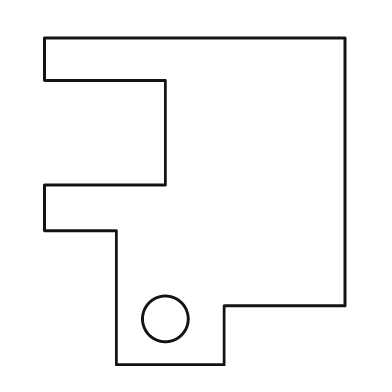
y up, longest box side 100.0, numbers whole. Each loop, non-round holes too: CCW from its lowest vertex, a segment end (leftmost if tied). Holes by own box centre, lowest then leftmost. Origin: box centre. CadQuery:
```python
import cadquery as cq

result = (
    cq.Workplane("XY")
    .moveTo(-24.0, -50.0)
    .lineTo(9.0, -50.0)
    .lineTo(9.0, -32.0)
    .lineTo(46.0, -32.0)
    .lineTo(46.0, 50.0)
    .lineTo(-46.0, 50.0)
    .lineTo(-46.0, 37.0)
    .lineTo(-9.0, 37.0)
    .lineTo(-9.0, 5.0)
    .lineTo(-46.0, 5.0)
    .lineTo(-46.0, -9.0)
    .lineTo(-24.0, -9.0)
    .close()
    .moveTo(-9.0, -36.0)
    .circle(7.0)
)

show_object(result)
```